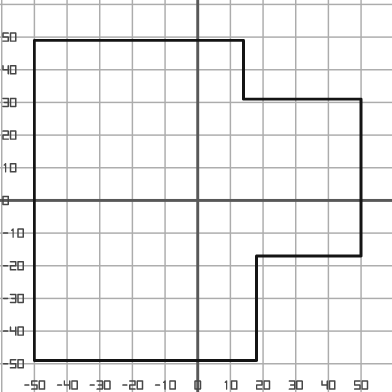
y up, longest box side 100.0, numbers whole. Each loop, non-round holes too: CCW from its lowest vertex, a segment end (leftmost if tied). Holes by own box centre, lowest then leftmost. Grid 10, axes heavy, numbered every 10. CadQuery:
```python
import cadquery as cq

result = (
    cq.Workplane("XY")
    .moveTo(-50.0, -49.0)
    .lineTo(18.0, -49.0)
    .lineTo(18.0, -17.0)
    .lineTo(50.0, -17.0)
    .lineTo(50.0, 31.0)
    .lineTo(14.0, 31.0)
    .lineTo(14.0, 49.0)
    .lineTo(-50.0, 49.0)
    .close()
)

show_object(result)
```